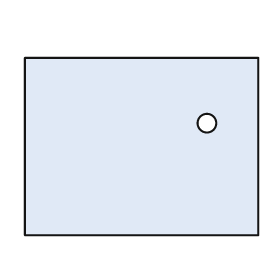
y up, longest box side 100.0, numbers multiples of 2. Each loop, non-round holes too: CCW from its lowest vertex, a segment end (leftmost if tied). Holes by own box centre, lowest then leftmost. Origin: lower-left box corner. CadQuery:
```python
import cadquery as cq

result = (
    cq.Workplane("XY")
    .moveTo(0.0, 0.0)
    .lineTo(100.0, 0.0)
    .lineTo(100.0, 76.0)
    .lineTo(0.0, 76.0)
    .close()
    .moveTo(78.0, 48.0)
    .circle(4.0)
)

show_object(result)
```